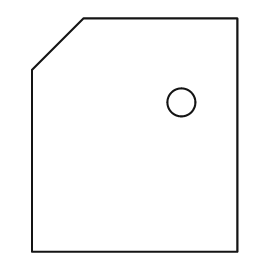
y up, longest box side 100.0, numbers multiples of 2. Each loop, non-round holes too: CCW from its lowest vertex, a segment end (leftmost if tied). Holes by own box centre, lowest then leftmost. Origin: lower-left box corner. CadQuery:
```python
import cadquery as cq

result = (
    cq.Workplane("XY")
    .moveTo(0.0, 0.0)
    .lineTo(88.0, 0.0)
    .lineTo(88.0, 100.0)
    .lineTo(22.0, 100.0)
    .lineTo(0.0, 78.0)
    .close()
    .moveTo(64.0, 64.0)
    .circle(6.0)
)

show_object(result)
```